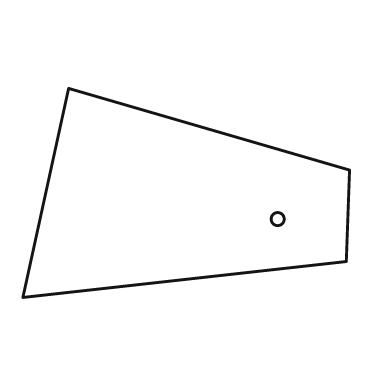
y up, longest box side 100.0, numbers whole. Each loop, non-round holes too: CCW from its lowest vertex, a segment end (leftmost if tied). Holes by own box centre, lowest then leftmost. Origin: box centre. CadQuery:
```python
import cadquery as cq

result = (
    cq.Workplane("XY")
    .moveTo(-50.0, -32.0)
    .lineTo(49.0, -21.0)
    .lineTo(50.0, 7.0)
    .lineTo(-36.0, 32.0)
    .close()
    .moveTo(28.0, -8.0)
    .circle(2.0)
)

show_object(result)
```